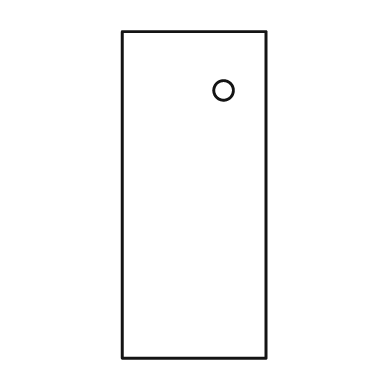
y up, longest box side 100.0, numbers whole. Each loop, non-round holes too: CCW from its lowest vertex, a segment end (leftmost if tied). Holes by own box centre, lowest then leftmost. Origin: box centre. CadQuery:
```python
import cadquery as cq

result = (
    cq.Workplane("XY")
    .moveTo(-22.0, -50.0)
    .lineTo(22.0, -50.0)
    .lineTo(22.0, 50.0)
    .lineTo(-22.0, 50.0)
    .close()
    .moveTo(9.0, 32.0)
    .circle(3.0)
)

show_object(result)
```